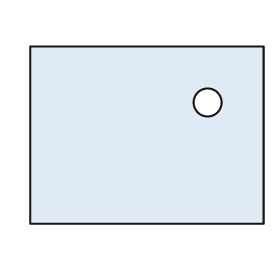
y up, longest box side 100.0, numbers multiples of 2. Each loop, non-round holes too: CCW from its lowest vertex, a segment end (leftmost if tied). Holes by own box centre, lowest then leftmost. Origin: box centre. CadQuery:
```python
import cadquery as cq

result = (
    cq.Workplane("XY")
    .moveTo(-50.0, -38.0)
    .lineTo(50.0, -38.0)
    .lineTo(50.0, 38.0)
    .lineTo(-50.0, 38.0)
    .close()
    .moveTo(26.0, 14.0)
    .circle(6.0)
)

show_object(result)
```